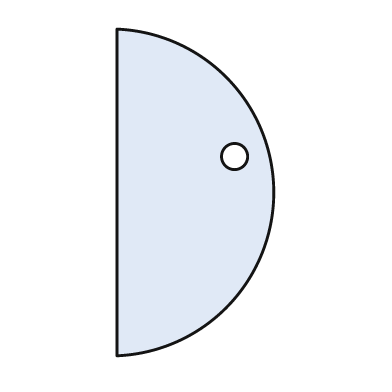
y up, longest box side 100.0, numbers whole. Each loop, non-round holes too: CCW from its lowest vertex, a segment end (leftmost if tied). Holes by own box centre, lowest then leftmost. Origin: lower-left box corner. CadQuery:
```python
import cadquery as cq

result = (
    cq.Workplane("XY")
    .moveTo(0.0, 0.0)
    .threePointArc((48.0, 50.0), (0.0, 100.0))
    .close()
    .moveTo(36.0, 61.0)
    .circle(4.0)
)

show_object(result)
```